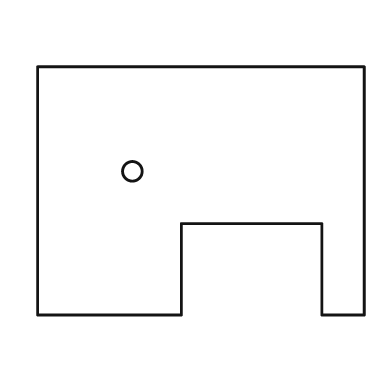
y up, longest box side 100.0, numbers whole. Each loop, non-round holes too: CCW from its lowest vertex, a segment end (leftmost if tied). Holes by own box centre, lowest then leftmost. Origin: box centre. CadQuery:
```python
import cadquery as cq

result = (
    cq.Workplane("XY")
    .moveTo(-50.0, -38.0)
    .lineTo(-6.0, -38.0)
    .lineTo(-6.0, -10.0)
    .lineTo(37.0, -10.0)
    .lineTo(37.0, -38.0)
    .lineTo(50.0, -38.0)
    .lineTo(50.0, 38.0)
    .lineTo(-50.0, 38.0)
    .close()
    .moveTo(-21.0, 6.0)
    .circle(3.0)
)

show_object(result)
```